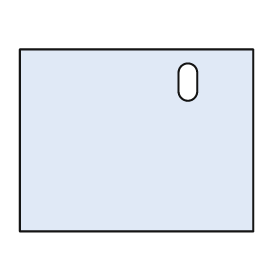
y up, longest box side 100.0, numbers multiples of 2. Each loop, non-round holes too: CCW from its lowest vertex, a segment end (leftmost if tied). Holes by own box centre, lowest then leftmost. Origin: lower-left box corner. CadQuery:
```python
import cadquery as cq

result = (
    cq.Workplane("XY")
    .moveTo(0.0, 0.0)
    .lineTo(100.0, 0.0)
    .lineTo(100.0, 78.0)
    .lineTo(0.0, 78.0)
    .close()
    .moveTo(68.0, 60.0)
    .threePointArc((72.0, 56.0), (76.0, 60.0))
    .lineTo(76.0, 68.0)
    .threePointArc((72.0, 72.0), (68.0, 68.0))
    .close()
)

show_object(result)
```